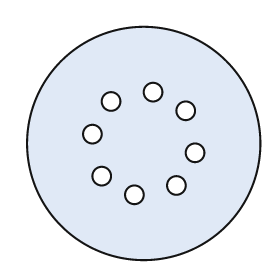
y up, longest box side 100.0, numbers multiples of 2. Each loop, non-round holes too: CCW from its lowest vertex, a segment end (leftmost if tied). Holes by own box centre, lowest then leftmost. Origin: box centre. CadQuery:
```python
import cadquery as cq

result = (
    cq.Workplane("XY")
    .moveTo(0.0, 0.0)
    .circle(50.0)
    .moveTo(-4.0, -22.0)
    .circle(4.0)
    .moveTo(14.0, -18.0)
    .circle(4.0)
    .moveTo(-18.0, -14.0)
    .circle(4.0)
    .moveTo(22.0, -4.0)
    .circle(4.0)
    .moveTo(-22.0, 4.0)
    .circle(4.0)
    .moveTo(18.0, 14.0)
    .circle(4.0)
    .moveTo(-14.0, 18.0)
    .circle(4.0)
    .moveTo(4.0, 22.0)
    .circle(4.0)
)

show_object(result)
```